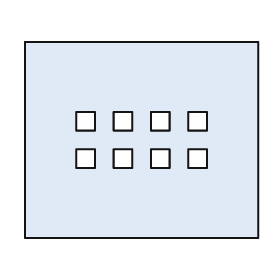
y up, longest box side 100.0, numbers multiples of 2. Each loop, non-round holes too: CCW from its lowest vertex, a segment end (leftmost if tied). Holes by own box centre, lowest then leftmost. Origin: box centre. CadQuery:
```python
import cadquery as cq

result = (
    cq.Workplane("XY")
    .moveTo(-50.0, -42.0)
    .lineTo(50.0, -42.0)
    .lineTo(50.0, 42.0)
    .lineTo(-50.0, 42.0)
    .close()
    .moveTo(-28.0, -12.0)
    .lineTo(-20.0, -12.0)
    .lineTo(-20.0, -4.0)
    .lineTo(-28.0, -4.0)
    .close()
    .moveTo(-12.0, -12.0)
    .lineTo(-4.0, -12.0)
    .lineTo(-4.0, -4.0)
    .lineTo(-12.0, -4.0)
    .close()
    .moveTo(4.0, -12.0)
    .lineTo(12.0, -12.0)
    .lineTo(12.0, -4.0)
    .lineTo(4.0, -4.0)
    .close()
    .moveTo(20.0, -12.0)
    .lineTo(28.0, -12.0)
    .lineTo(28.0, -4.0)
    .lineTo(20.0, -4.0)
    .close()
    .moveTo(-28.0, 4.0)
    .lineTo(-20.0, 4.0)
    .lineTo(-20.0, 12.0)
    .lineTo(-28.0, 12.0)
    .close()
    .moveTo(-12.0, 4.0)
    .lineTo(-4.0, 4.0)
    .lineTo(-4.0, 12.0)
    .lineTo(-12.0, 12.0)
    .close()
    .moveTo(4.0, 4.0)
    .lineTo(12.0, 4.0)
    .lineTo(12.0, 12.0)
    .lineTo(4.0, 12.0)
    .close()
    .moveTo(20.0, 4.0)
    .lineTo(28.0, 4.0)
    .lineTo(28.0, 12.0)
    .lineTo(20.0, 12.0)
    .close()
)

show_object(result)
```